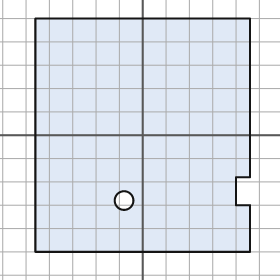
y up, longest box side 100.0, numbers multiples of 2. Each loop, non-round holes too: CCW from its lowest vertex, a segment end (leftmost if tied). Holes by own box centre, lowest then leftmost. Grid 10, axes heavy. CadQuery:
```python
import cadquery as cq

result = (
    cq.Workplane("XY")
    .moveTo(-46.0, -50.0)
    .lineTo(46.0, -50.0)
    .lineTo(46.0, -30.0)
    .lineTo(40.0, -30.0)
    .lineTo(40.0, -18.0)
    .lineTo(46.0, -18.0)
    .lineTo(46.0, 50.0)
    .lineTo(-46.0, 50.0)
    .close()
    .moveTo(-8.0, -28.0)
    .circle(4.0)
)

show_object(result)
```